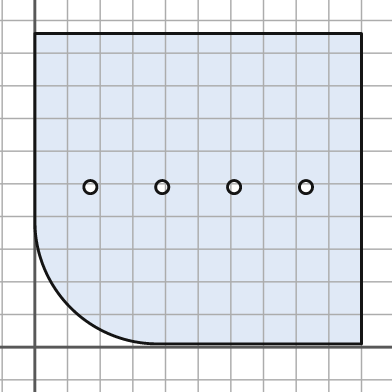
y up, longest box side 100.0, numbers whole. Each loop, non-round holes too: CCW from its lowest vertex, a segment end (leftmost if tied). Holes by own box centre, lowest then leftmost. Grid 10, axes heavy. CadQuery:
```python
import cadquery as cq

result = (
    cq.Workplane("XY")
    .moveTo(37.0, 1.0)
    .lineTo(100.0, 1.0)
    .lineTo(100.0, 96.0)
    .lineTo(0.0, 96.0)
    .lineTo(0.0, 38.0)
    .threePointArc((11.0, 12.0), (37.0, 1.0))
    .close()
    .moveTo(17.0, 49.0)
    .circle(2.0)
    .moveTo(39.0, 49.0)
    .circle(2.0)
    .moveTo(61.0, 49.0)
    .circle(2.0)
    .moveTo(83.0, 49.0)
    .circle(2.0)
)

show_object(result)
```